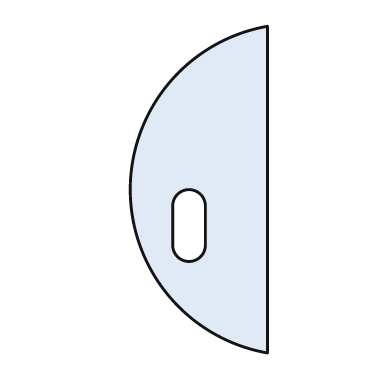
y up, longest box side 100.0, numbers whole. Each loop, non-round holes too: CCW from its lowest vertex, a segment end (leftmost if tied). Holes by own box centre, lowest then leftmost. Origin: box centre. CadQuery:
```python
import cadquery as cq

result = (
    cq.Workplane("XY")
    .moveTo(21.0, -50.0)
    .lineTo(21.0, 50.0)
    .threePointArc((-21.0, 0.0), (21.0, -50.0))
    .close()
    .moveTo(-8.0, -17.0)
    .threePointArc((-3.0, -22.0), (2.0, -17.0))
    .lineTo(2.0, -5.0)
    .threePointArc((-3.0, 0.0), (-8.0, -5.0))
    .close()
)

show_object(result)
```